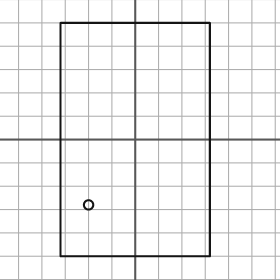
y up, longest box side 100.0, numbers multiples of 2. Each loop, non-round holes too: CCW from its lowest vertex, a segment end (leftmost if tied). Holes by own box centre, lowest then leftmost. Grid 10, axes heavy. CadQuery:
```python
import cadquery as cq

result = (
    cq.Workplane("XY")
    .moveTo(-32.0, -50.0)
    .lineTo(32.0, -50.0)
    .lineTo(32.0, 50.0)
    .lineTo(-32.0, 50.0)
    .close()
    .moveTo(-20.0, -28.0)
    .circle(2.0)
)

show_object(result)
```